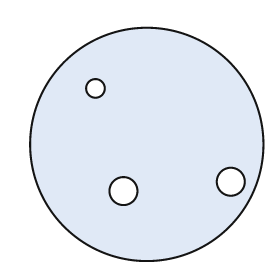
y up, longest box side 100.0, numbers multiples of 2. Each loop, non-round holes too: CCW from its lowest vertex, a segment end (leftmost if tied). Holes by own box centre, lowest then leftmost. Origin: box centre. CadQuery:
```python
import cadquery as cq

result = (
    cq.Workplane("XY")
    .moveTo(0.0, 0.0)
    .circle(50.0)
    .moveTo(-10.0, -20.0)
    .circle(6.0)
    .moveTo(36.0, -16.0)
    .circle(6.0)
    .moveTo(-22.0, 24.0)
    .circle(4.0)
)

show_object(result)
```